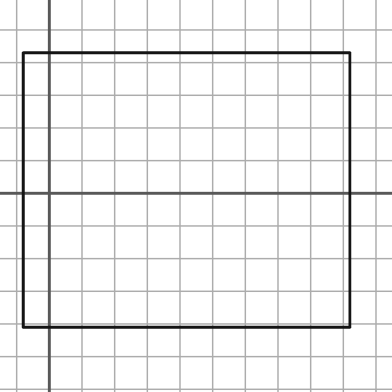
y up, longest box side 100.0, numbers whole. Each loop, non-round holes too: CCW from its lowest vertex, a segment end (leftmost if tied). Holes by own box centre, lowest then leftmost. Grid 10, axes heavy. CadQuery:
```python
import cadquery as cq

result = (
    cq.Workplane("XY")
    .moveTo(-8.0, -41.0)
    .lineTo(92.0, -41.0)
    .lineTo(92.0, 43.0)
    .lineTo(-8.0, 43.0)
    .close()
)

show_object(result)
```